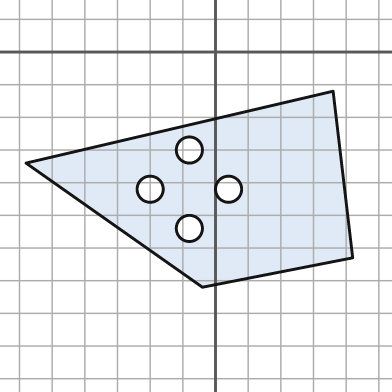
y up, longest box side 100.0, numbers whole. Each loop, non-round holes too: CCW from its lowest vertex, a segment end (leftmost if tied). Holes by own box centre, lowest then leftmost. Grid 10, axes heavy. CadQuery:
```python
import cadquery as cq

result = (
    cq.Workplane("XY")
    .moveTo(-4.0, -72.0)
    .lineTo(42.0, -63.0)
    .lineTo(36.0, -12.0)
    .lineTo(-58.0, -34.0)
    .close()
    .moveTo(-8.0, -54.0)
    .circle(4.0)
    .moveTo(-20.0, -42.0)
    .circle(4.0)
    .moveTo(4.0, -42.0)
    .circle(4.0)
    .moveTo(-8.0, -30.0)
    .circle(4.0)
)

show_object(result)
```